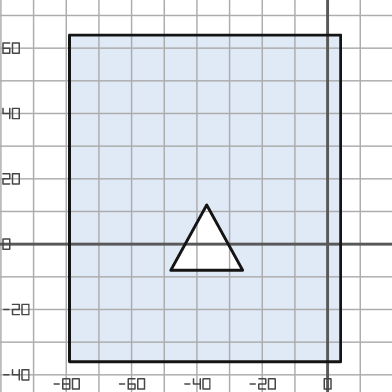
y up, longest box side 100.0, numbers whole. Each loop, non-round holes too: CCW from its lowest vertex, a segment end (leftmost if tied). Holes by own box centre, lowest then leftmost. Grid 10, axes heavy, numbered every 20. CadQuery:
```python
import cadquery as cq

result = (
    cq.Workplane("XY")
    .moveTo(-79.0, -36.0)
    .lineTo(4.0, -36.0)
    .lineTo(4.0, 64.0)
    .lineTo(-79.0, 64.0)
    .close()
    .moveTo(-48.0, -8.0)
    .lineTo(-26.0, -8.0)
    .lineTo(-37.0, 12.0)
    .close()
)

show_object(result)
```